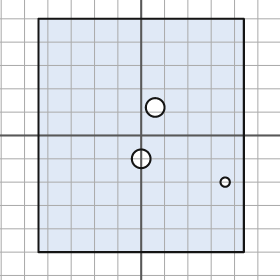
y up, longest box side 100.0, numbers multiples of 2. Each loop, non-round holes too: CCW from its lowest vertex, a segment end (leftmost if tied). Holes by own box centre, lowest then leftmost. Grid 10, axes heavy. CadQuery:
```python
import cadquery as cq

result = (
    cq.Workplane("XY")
    .moveTo(-44.0, -50.0)
    .lineTo(44.0, -50.0)
    .lineTo(44.0, 50.0)
    .lineTo(-44.0, 50.0)
    .close()
    .moveTo(36.0, -20.0)
    .circle(2.0)
    .moveTo(0.0, -10.0)
    .circle(4.0)
    .moveTo(6.0, 12.0)
    .circle(4.0)
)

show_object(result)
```